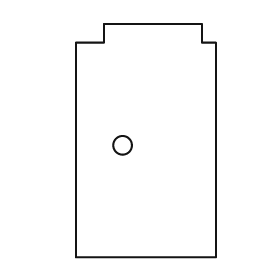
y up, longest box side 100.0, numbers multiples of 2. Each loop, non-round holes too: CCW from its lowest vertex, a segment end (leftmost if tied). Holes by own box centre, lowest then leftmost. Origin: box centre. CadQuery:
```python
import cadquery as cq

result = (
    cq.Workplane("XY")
    .moveTo(-30.0, -50.0)
    .lineTo(30.0, -50.0)
    .lineTo(30.0, 42.0)
    .lineTo(24.0, 42.0)
    .lineTo(24.0, 50.0)
    .lineTo(-18.0, 50.0)
    .lineTo(-18.0, 42.0)
    .lineTo(-30.0, 42.0)
    .close()
    .moveTo(-10.0, -2.0)
    .circle(4.0)
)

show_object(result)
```